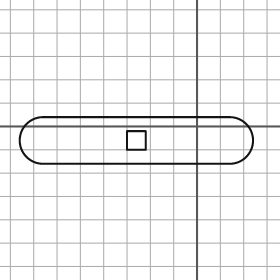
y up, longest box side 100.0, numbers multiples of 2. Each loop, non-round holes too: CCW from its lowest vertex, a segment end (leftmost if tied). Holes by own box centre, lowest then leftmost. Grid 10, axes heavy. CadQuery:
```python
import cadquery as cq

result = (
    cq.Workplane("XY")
    .moveTo(-66.0, -16.0)
    .lineTo(14.0, -16.0)
    .threePointArc((24.0, -6.0), (14.0, 4.0))
    .lineTo(-66.0, 4.0)
    .threePointArc((-76.0, -6.0), (-66.0, -16.0))
    .close()
    .moveTo(-30.0, -10.0)
    .lineTo(-22.0, -10.0)
    .lineTo(-22.0, -2.0)
    .lineTo(-30.0, -2.0)
    .close()
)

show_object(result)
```